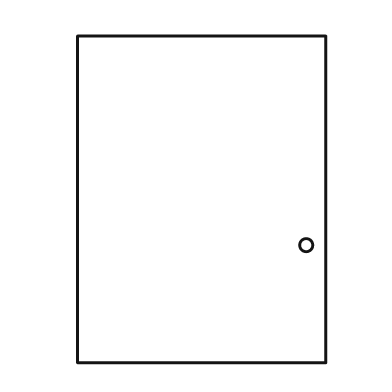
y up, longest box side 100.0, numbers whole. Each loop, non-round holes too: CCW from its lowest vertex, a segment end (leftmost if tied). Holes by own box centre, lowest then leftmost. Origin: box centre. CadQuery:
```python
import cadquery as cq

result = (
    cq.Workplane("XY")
    .moveTo(-38.0, -50.0)
    .lineTo(38.0, -50.0)
    .lineTo(38.0, 50.0)
    .lineTo(-38.0, 50.0)
    .close()
    .moveTo(32.0, -14.0)
    .circle(2.0)
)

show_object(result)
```